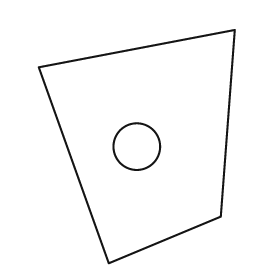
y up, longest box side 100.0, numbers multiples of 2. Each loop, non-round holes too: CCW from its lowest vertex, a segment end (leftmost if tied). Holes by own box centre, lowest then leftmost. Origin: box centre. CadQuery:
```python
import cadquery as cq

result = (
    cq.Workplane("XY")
    .moveTo(-12.0, -50.0)
    .lineTo(36.0, -30.0)
    .lineTo(42.0, 50.0)
    .lineTo(-42.0, 34.0)
    .close()
    .moveTo(0.0, 0.0)
    .circle(10.0)
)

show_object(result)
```